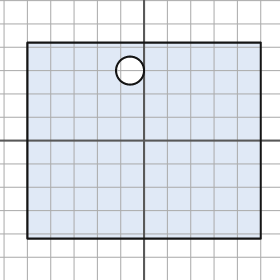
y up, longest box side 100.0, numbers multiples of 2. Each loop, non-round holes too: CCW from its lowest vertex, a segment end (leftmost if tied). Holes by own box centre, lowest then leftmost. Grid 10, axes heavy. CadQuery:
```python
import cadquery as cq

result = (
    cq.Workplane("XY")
    .moveTo(-50.0, -42.0)
    .lineTo(50.0, -42.0)
    .lineTo(50.0, 42.0)
    .lineTo(-50.0, 42.0)
    .close()
    .moveTo(-6.0, 30.0)
    .circle(6.0)
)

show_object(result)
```